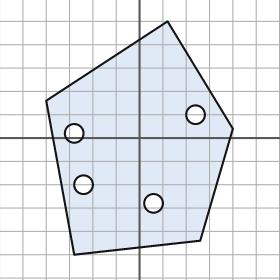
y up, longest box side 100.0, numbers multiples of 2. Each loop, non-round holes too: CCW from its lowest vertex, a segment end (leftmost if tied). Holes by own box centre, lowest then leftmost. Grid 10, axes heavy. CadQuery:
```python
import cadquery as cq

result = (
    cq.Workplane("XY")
    .moveTo(-28.0, -50.0)
    .lineTo(26.0, -44.0)
    .lineTo(40.0, 4.0)
    .lineTo(12.0, 50.0)
    .lineTo(-40.0, 16.0)
    .close()
    .moveTo(6.0, -28.0)
    .circle(4.0)
    .moveTo(-24.0, -20.0)
    .circle(4.0)
    .moveTo(-28.0, 2.0)
    .circle(4.0)
    .moveTo(24.0, 10.0)
    .circle(4.0)
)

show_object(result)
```